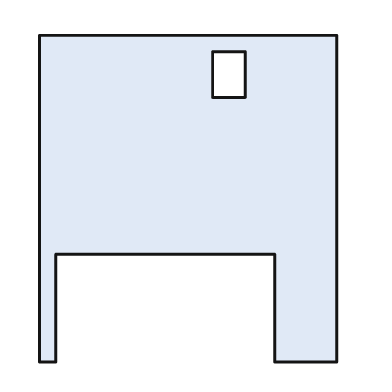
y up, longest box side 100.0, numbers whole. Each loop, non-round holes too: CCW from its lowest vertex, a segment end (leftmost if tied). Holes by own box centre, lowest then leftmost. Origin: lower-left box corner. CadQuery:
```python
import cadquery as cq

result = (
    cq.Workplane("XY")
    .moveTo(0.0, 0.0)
    .lineTo(5.0, 0.0)
    .lineTo(5.0, 33.0)
    .lineTo(72.0, 33.0)
    .lineTo(72.0, 0.0)
    .lineTo(91.0, 0.0)
    .lineTo(91.0, 100.0)
    .lineTo(0.0, 100.0)
    .close()
    .moveTo(53.0, 81.0)
    .lineTo(63.0, 81.0)
    .lineTo(63.0, 95.0)
    .lineTo(53.0, 95.0)
    .close()
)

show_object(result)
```